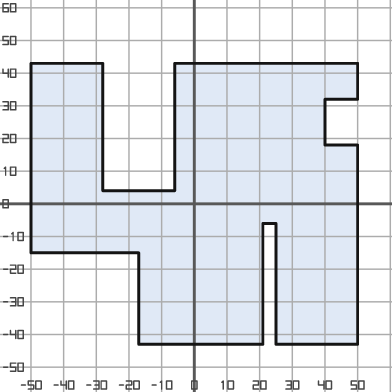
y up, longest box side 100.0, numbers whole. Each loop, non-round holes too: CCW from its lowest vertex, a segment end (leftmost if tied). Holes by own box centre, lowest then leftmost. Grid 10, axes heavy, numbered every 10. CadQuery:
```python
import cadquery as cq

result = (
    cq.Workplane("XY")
    .moveTo(-17.0, -43.0)
    .lineTo(21.0, -43.0)
    .lineTo(21.0, -6.0)
    .lineTo(25.0, -6.0)
    .lineTo(25.0, -43.0)
    .lineTo(50.0, -43.0)
    .lineTo(50.0, 18.0)
    .lineTo(40.0, 18.0)
    .lineTo(40.0, 32.0)
    .lineTo(50.0, 32.0)
    .lineTo(50.0, 43.0)
    .lineTo(-6.0, 43.0)
    .lineTo(-6.0, 4.0)
    .lineTo(-28.0, 4.0)
    .lineTo(-28.0, 43.0)
    .lineTo(-50.0, 43.0)
    .lineTo(-50.0, -15.0)
    .lineTo(-17.0, -15.0)
    .close()
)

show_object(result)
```